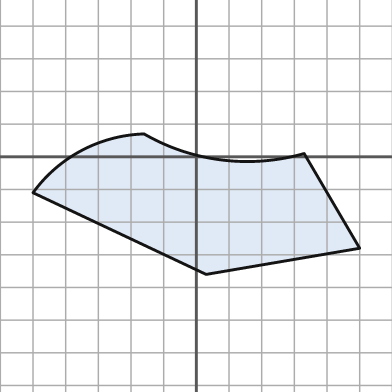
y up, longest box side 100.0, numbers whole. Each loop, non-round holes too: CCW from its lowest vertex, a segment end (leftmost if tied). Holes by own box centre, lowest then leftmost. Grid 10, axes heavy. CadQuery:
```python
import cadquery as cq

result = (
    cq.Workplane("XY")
    .moveTo(3.0, -36.0)
    .lineTo(50.0, -28.0)
    .lineTo(33.0, 1.0)
    .threePointArc((8.0, -1.0), (-16.0, 7.0))
    .threePointArc((-35.0, 2.0), (-50.0, -11.0))
    .close()
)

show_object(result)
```